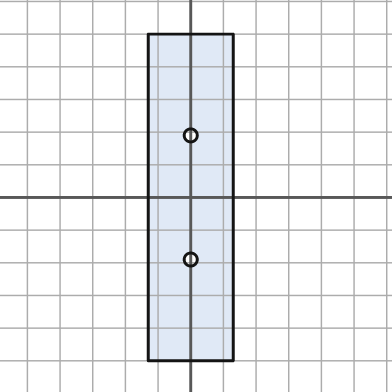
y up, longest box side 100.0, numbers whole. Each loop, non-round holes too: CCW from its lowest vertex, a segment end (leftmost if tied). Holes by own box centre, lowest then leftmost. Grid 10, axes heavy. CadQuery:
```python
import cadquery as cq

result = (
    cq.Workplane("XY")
    .moveTo(-13.0, -50.0)
    .lineTo(13.0, -50.0)
    .lineTo(13.0, 50.0)
    .lineTo(-13.0, 50.0)
    .close()
    .moveTo(0.0, -19.0)
    .circle(2.0)
    .moveTo(0.0, 19.0)
    .circle(2.0)
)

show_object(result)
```